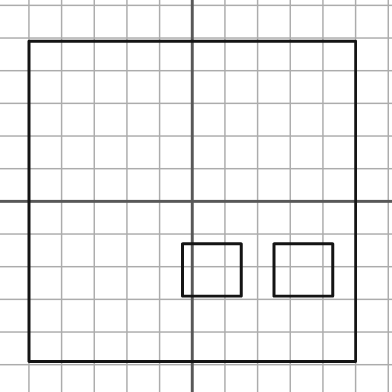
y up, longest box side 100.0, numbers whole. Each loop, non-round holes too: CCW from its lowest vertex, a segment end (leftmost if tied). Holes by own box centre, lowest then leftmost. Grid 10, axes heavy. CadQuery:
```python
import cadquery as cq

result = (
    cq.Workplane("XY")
    .moveTo(-50.0, -49.0)
    .lineTo(50.0, -49.0)
    .lineTo(50.0, 49.0)
    .lineTo(-50.0, 49.0)
    .close()
    .moveTo(-3.0, -29.0)
    .lineTo(15.0, -29.0)
    .lineTo(15.0, -13.0)
    .lineTo(-3.0, -13.0)
    .close()
    .moveTo(25.0, -29.0)
    .lineTo(43.0, -29.0)
    .lineTo(43.0, -13.0)
    .lineTo(25.0, -13.0)
    .close()
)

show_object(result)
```